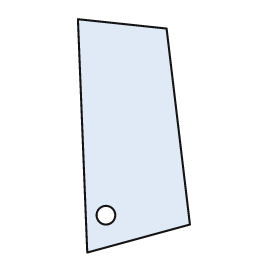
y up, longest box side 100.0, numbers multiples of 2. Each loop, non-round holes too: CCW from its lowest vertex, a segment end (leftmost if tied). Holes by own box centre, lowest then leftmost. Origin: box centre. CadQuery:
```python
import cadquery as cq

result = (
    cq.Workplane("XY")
    .moveTo(-20.0, -50.0)
    .lineTo(24.0, -38.0)
    .lineTo(14.0, 46.0)
    .lineTo(-24.0, 50.0)
    .close()
    .moveTo(-12.0, -34.0)
    .circle(4.0)
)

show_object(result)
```